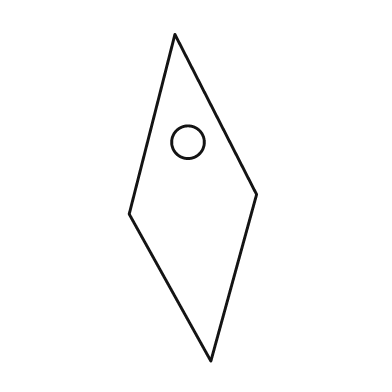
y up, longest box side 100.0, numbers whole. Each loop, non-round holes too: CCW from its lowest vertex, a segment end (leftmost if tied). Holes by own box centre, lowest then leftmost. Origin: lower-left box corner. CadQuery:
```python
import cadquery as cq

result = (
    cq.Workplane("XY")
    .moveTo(25.0, 0.0)
    .lineTo(39.0, 51.0)
    .lineTo(14.0, 100.0)
    .lineTo(0.0, 45.0)
    .close()
    .moveTo(18.0, 67.0)
    .circle(5.0)
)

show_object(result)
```